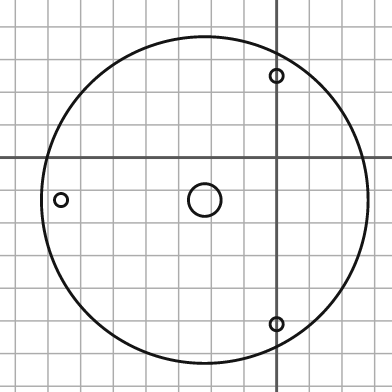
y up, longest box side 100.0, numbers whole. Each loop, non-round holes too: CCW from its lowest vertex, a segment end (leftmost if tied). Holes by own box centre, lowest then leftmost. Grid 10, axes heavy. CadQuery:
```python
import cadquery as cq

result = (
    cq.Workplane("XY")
    .moveTo(-22.0, -13.0)
    .circle(50.0)
    .moveTo(0.0, -51.0)
    .circle(2.0)
    .moveTo(-66.0, -13.0)
    .circle(2.0)
    .moveTo(-22.0, -13.0)
    .circle(5.0)
    .moveTo(0.0, 25.0)
    .circle(2.0)
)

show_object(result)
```